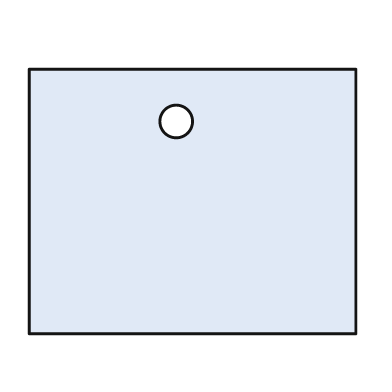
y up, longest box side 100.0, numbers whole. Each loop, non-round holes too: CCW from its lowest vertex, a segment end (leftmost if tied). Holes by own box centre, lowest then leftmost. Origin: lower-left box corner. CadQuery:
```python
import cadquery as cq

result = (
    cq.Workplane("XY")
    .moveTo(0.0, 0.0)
    .lineTo(100.0, 0.0)
    .lineTo(100.0, 81.0)
    .lineTo(0.0, 81.0)
    .close()
    .moveTo(45.0, 65.0)
    .circle(5.0)
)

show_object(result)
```